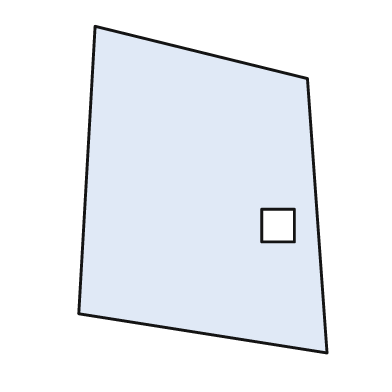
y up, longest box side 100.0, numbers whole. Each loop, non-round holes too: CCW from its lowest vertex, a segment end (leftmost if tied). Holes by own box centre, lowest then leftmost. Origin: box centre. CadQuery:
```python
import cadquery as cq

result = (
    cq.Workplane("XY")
    .moveTo(38.0, -50.0)
    .lineTo(32.0, 34.0)
    .lineTo(-33.0, 50.0)
    .lineTo(-38.0, -38.0)
    .close()
    .moveTo(18.0, -16.0)
    .lineTo(28.0, -16.0)
    .lineTo(28.0, -6.0)
    .lineTo(18.0, -6.0)
    .close()
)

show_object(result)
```